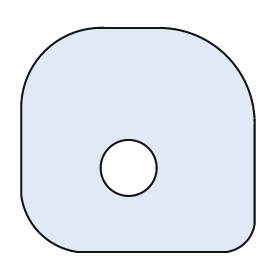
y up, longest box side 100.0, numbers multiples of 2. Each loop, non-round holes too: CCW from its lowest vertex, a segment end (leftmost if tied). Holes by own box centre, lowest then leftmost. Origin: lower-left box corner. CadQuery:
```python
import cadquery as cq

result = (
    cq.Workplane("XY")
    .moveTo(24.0, 0.0)
    .lineTo(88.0, 0.0)
    .threePointArc((96.0, 4.0), (100.0, 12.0))
    .lineTo(100.0, 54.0)
    .threePointArc((88.0, 84.0), (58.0, 96.0))
    .lineTo(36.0, 96.0)
    .threePointArc((10.0, 86.0), (0.0, 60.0))
    .lineTo(0.0, 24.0)
    .threePointArc((8.0, 8.0), (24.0, 0.0))
    .close()
    .moveTo(46.0, 36.0)
    .circle(12.0)
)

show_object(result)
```